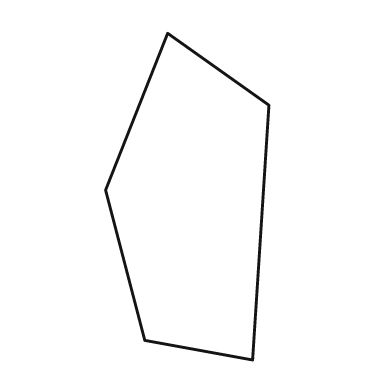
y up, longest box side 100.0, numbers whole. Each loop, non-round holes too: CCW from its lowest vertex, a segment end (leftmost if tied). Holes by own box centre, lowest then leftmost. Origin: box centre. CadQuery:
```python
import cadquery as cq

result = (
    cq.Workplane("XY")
    .moveTo(20.0, -50.0)
    .lineTo(25.0, 28.0)
    .lineTo(-6.0, 50.0)
    .lineTo(-25.0, 2.0)
    .lineTo(-13.0, -44.0)
    .close()
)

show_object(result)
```